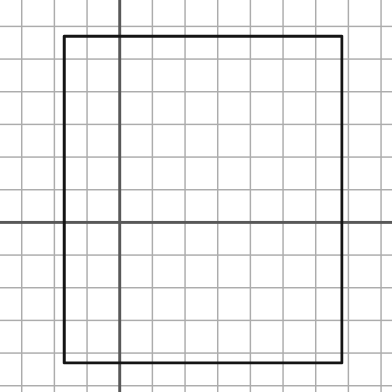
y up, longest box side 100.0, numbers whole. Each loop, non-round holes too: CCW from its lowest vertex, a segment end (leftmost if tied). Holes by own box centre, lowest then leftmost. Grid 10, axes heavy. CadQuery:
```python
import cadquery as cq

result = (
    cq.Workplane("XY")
    .moveTo(-17.0, -43.0)
    .lineTo(68.0, -43.0)
    .lineTo(68.0, 57.0)
    .lineTo(-17.0, 57.0)
    .close()
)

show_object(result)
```